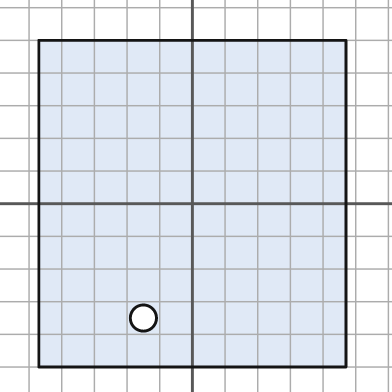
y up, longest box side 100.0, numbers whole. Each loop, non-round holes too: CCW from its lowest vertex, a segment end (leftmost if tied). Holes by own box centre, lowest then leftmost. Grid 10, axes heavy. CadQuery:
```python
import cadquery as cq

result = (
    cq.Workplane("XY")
    .moveTo(-47.0, -50.0)
    .lineTo(47.0, -50.0)
    .lineTo(47.0, 50.0)
    .lineTo(-47.0, 50.0)
    .close()
    .moveTo(-15.0, -35.0)
    .circle(4.0)
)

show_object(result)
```